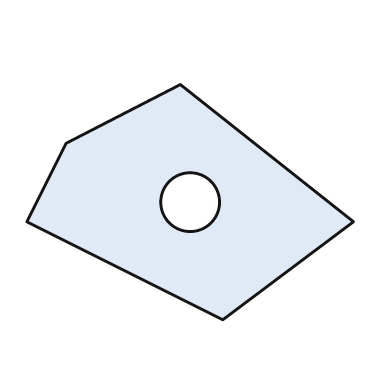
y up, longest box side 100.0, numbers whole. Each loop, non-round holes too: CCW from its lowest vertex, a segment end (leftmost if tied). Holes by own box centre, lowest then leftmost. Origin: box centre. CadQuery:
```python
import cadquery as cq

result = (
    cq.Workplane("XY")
    .moveTo(10.0, -36.0)
    .lineTo(50.0, -6.0)
    .lineTo(-3.0, 36.0)
    .lineTo(-38.0, 18.0)
    .lineTo(-50.0, -6.0)
    .close()
    .moveTo(0.0, 0.0)
    .circle(9.0)
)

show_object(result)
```